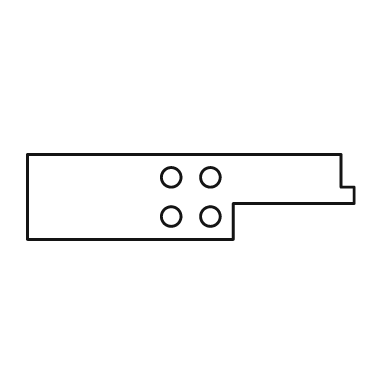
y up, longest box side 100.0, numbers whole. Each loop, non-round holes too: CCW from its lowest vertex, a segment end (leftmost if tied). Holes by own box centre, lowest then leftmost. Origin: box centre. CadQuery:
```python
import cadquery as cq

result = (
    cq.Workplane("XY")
    .moveTo(-50.0, -13.0)
    .lineTo(13.0, -13.0)
    .lineTo(13.0, -2.0)
    .lineTo(50.0, -2.0)
    .lineTo(50.0, 3.0)
    .lineTo(46.0, 3.0)
    .lineTo(46.0, 13.0)
    .lineTo(-50.0, 13.0)
    .close()
    .moveTo(-6.0, -6.0)
    .circle(3.0)
    .moveTo(6.0, -6.0)
    .circle(3.0)
    .moveTo(-6.0, 6.0)
    .circle(3.0)
    .moveTo(6.0, 6.0)
    .circle(3.0)
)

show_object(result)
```